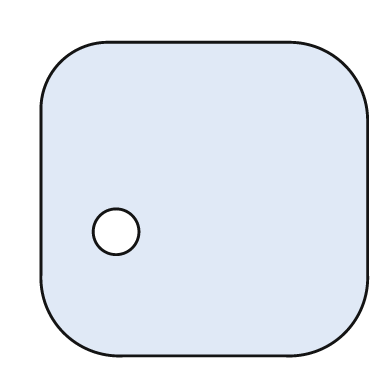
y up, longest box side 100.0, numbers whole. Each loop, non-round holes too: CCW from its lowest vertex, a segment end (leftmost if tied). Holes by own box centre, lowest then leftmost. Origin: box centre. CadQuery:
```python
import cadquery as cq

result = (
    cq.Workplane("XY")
    .moveTo(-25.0, -48.0)
    .lineTo(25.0, -48.0)
    .threePointArc((43.0, -41.0), (50.0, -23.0))
    .lineTo(50.0, 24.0)
    .threePointArc((43.0, 41.0), (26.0, 48.0))
    .lineTo(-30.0, 48.0)
    .threePointArc((-44.0, 42.0), (-50.0, 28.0))
    .lineTo(-50.0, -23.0)
    .threePointArc((-43.0, -41.0), (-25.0, -48.0))
    .close()
    .moveTo(-27.0, -10.0)
    .circle(7.0)
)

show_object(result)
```